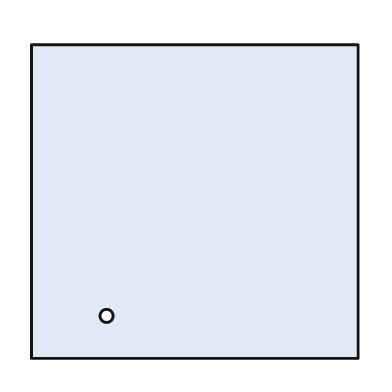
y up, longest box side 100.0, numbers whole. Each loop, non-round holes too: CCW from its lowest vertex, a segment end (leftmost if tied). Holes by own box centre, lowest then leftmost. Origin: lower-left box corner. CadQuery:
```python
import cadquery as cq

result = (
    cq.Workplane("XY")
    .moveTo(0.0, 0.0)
    .lineTo(100.0, 0.0)
    .lineTo(100.0, 96.0)
    .lineTo(0.0, 96.0)
    .close()
    .moveTo(23.0, 13.0)
    .circle(2.0)
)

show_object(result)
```